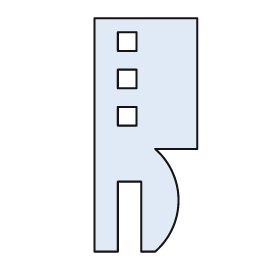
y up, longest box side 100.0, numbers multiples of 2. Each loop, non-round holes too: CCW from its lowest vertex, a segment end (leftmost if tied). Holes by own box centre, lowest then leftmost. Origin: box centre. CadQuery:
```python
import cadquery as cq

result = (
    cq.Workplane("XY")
    .moveTo(-22.0, -50.0)
    .lineTo(-12.0, -50.0)
    .lineTo(-12.0, -20.0)
    .lineTo(-2.0, -20.0)
    .lineTo(-2.0, -50.0)
    .lineTo(4.0, -50.0)
    .threePointArc((14.0, -28.0), (4.0, -6.0))
    .lineTo(22.0, -6.0)
    .lineTo(22.0, 50.0)
    .lineTo(-22.0, 50.0)
    .close()
    .moveTo(-12.0, 4.0)
    .lineTo(-4.0, 4.0)
    .lineTo(-4.0, 12.0)
    .lineTo(-12.0, 12.0)
    .close()
    .moveTo(-12.0, 20.0)
    .lineTo(-4.0, 20.0)
    .lineTo(-4.0, 28.0)
    .lineTo(-12.0, 28.0)
    .close()
    .moveTo(-12.0, 36.0)
    .lineTo(-4.0, 36.0)
    .lineTo(-4.0, 44.0)
    .lineTo(-12.0, 44.0)
    .close()
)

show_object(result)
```